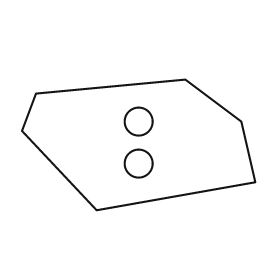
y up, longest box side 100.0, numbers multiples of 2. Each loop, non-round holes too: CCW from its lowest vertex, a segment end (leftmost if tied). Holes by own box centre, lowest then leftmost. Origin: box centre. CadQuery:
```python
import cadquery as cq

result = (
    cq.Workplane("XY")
    .moveTo(-18.0, -28.0)
    .lineTo(50.0, -16.0)
    .lineTo(44.0, 10.0)
    .lineTo(20.0, 28.0)
    .lineTo(-44.0, 22.0)
    .lineTo(-50.0, 6.0)
    .close()
    .moveTo(0.0, -8.0)
    .circle(6.0)
    .moveTo(0.0, 10.0)
    .circle(6.0)
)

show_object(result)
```